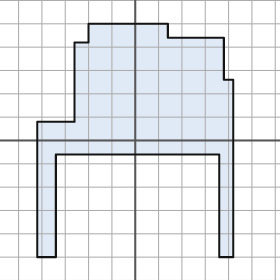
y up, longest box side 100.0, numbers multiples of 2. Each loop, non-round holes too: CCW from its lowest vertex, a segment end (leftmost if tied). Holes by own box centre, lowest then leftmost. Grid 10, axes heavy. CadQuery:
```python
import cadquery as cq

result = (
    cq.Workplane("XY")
    .moveTo(-42.0, -50.0)
    .lineTo(-34.0, -50.0)
    .lineTo(-34.0, -6.0)
    .lineTo(36.0, -6.0)
    .lineTo(36.0, -50.0)
    .lineTo(42.0, -50.0)
    .lineTo(42.0, 26.0)
    .lineTo(38.0, 26.0)
    .lineTo(38.0, 44.0)
    .lineTo(14.0, 44.0)
    .lineTo(14.0, 50.0)
    .lineTo(-20.0, 50.0)
    .lineTo(-20.0, 42.0)
    .lineTo(-26.0, 42.0)
    .lineTo(-26.0, 8.0)
    .lineTo(-42.0, 8.0)
    .close()
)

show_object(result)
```